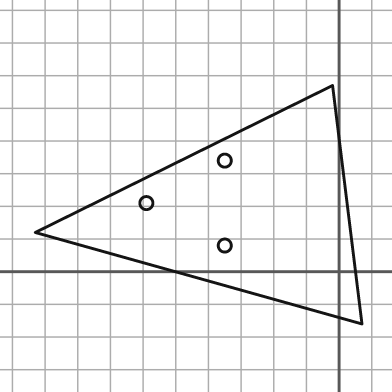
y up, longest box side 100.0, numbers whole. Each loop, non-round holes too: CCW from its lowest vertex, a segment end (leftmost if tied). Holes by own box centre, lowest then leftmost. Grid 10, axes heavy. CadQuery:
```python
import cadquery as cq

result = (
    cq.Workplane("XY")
    .moveTo(7.0, -16.0)
    .lineTo(-2.0, 57.0)
    .lineTo(-93.0, 12.0)
    .close()
    .moveTo(-35.0, 8.0)
    .circle(2.0)
    .moveTo(-59.0, 21.0)
    .circle(2.0)
    .moveTo(-35.0, 34.0)
    .circle(2.0)
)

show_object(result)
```